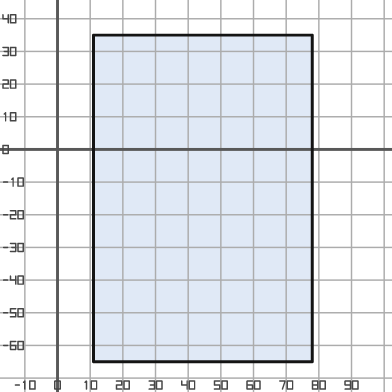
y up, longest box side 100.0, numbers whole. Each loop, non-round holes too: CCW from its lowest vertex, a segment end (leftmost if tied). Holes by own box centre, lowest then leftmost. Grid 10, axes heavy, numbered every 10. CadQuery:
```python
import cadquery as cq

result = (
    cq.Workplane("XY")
    .moveTo(11.0, -65.0)
    .lineTo(78.0, -65.0)
    .lineTo(78.0, 35.0)
    .lineTo(11.0, 35.0)
    .close()
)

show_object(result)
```